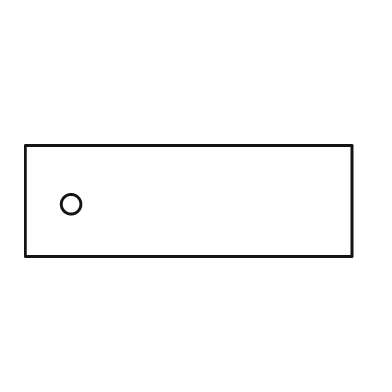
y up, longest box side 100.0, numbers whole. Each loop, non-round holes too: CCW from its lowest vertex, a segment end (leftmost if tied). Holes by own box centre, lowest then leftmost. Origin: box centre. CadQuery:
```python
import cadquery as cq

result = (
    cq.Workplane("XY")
    .moveTo(-50.0, -17.0)
    .lineTo(50.0, -17.0)
    .lineTo(50.0, 17.0)
    .lineTo(-50.0, 17.0)
    .close()
    .moveTo(-36.0, -1.0)
    .circle(3.0)
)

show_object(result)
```